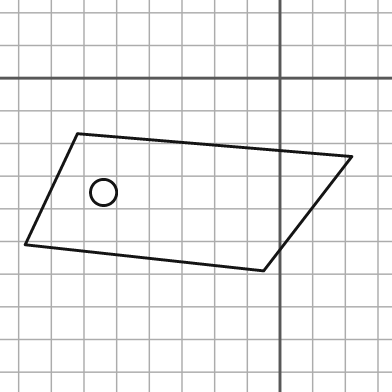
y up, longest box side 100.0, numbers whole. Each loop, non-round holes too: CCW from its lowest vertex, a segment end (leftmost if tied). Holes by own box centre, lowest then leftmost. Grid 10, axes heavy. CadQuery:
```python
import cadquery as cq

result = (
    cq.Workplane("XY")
    .moveTo(-5.0, -59.0)
    .lineTo(22.0, -24.0)
    .lineTo(-62.0, -17.0)
    .lineTo(-78.0, -51.0)
    .close()
    .moveTo(-54.0, -35.0)
    .circle(4.0)
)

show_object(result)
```